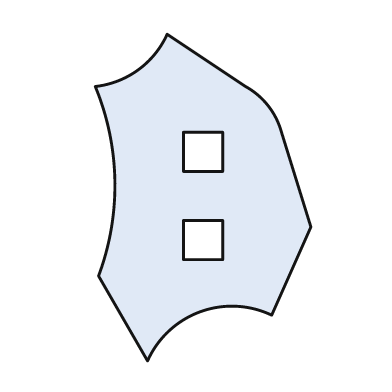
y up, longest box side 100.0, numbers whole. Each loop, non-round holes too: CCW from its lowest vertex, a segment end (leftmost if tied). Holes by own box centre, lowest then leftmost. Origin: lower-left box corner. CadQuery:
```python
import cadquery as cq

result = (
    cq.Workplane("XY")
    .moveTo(16.0, 0.0)
    .threePointArc((32.0, 15.0), (54.0, 14.0))
    .lineTo(66.0, 41.0)
    .lineTo(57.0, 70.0)
    .threePointArc((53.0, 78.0), (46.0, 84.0))
    .lineTo(22.0, 100.0)
    .threePointArc((13.0, 89.0), (0.0, 84.0))
    .threePointArc((6.0, 55.0), (1.0, 26.0))
    .close()
    .moveTo(27.0, 31.0)
    .lineTo(39.0, 31.0)
    .lineTo(39.0, 43.0)
    .lineTo(27.0, 43.0)
    .close()
    .moveTo(27.0, 58.0)
    .lineTo(39.0, 58.0)
    .lineTo(39.0, 70.0)
    .lineTo(27.0, 70.0)
    .close()
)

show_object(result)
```